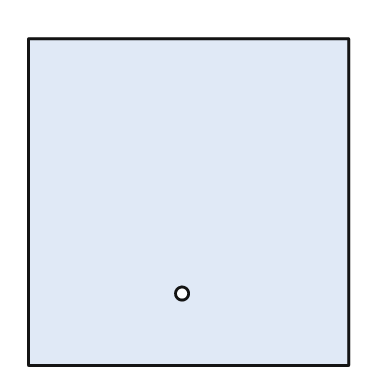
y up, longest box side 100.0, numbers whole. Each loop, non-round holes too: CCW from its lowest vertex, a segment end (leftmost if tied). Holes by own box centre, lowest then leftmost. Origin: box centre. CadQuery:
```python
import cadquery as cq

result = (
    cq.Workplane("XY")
    .moveTo(-49.0, -50.0)
    .lineTo(49.0, -50.0)
    .lineTo(49.0, 50.0)
    .lineTo(-49.0, 50.0)
    .close()
    .moveTo(-2.0, -28.0)
    .circle(2.0)
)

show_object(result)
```